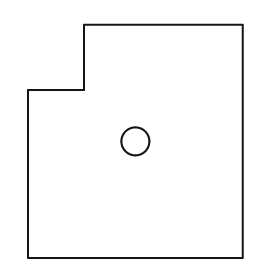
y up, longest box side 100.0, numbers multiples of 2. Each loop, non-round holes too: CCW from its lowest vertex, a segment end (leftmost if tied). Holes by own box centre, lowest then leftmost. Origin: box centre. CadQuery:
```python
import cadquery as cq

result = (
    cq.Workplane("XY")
    .moveTo(-46.0, -50.0)
    .lineTo(46.0, -50.0)
    .lineTo(46.0, 50.0)
    .lineTo(-22.0, 50.0)
    .lineTo(-22.0, 22.0)
    .lineTo(-46.0, 22.0)
    .close()
    .moveTo(0.0, 0.0)
    .circle(6.0)
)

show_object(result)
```